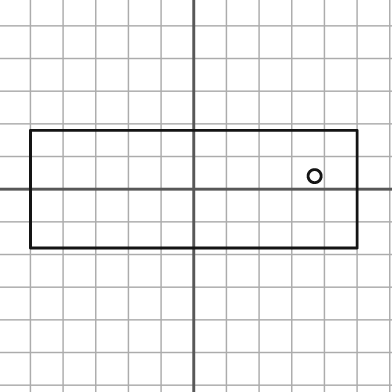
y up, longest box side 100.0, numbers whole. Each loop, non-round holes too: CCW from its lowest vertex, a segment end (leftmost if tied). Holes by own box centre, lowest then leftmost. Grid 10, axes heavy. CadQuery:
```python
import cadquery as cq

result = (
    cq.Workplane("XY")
    .moveTo(-50.0, -18.0)
    .lineTo(50.0, -18.0)
    .lineTo(50.0, 18.0)
    .lineTo(-50.0, 18.0)
    .close()
    .moveTo(37.0, 4.0)
    .circle(2.0)
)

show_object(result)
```